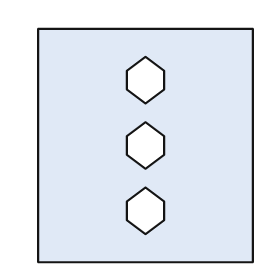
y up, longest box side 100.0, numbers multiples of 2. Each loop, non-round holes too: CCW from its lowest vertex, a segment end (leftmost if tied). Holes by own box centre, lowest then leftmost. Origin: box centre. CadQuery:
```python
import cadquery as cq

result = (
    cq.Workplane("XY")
    .moveTo(-46.0, -50.0)
    .lineTo(46.0, -50.0)
    .lineTo(46.0, 50.0)
    .lineTo(-46.0, 50.0)
    .close()
    .moveTo(0.0, -38.0)
    .lineTo(8.0, -32.0)
    .lineTo(8.0, -24.0)
    .lineTo(0.0, -18.0)
    .lineTo(-8.0, -24.0)
    .lineTo(-8.0, -32.0)
    .close()
    .moveTo(0.0, -10.0)
    .lineTo(8.0, -4.0)
    .lineTo(8.0, 4.0)
    .lineTo(0.0, 10.0)
    .lineTo(-8.0, 4.0)
    .lineTo(-8.0, -4.0)
    .close()
    .moveTo(0.0, 18.0)
    .lineTo(8.0, 24.0)
    .lineTo(8.0, 32.0)
    .lineTo(0.0, 38.0)
    .lineTo(-8.0, 32.0)
    .lineTo(-8.0, 24.0)
    .close()
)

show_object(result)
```